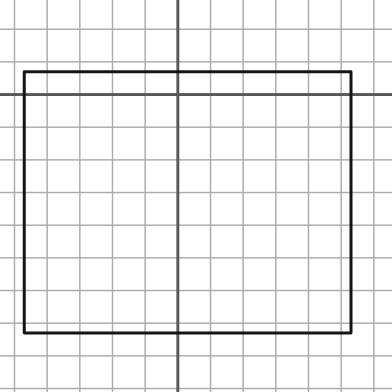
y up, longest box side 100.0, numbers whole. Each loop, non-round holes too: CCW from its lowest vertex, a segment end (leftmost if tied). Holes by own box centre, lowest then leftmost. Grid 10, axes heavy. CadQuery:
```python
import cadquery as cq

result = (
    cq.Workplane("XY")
    .moveTo(-47.0, -73.0)
    .lineTo(53.0, -73.0)
    .lineTo(53.0, 7.0)
    .lineTo(-47.0, 7.0)
    .close()
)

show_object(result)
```